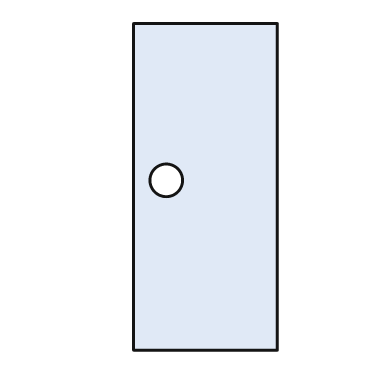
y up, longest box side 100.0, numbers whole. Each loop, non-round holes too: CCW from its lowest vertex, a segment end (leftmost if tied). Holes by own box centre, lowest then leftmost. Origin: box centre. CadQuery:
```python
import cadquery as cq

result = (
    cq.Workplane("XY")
    .moveTo(-22.0, -50.0)
    .lineTo(22.0, -50.0)
    .lineTo(22.0, 50.0)
    .lineTo(-22.0, 50.0)
    .close()
    .moveTo(-12.0, 2.0)
    .circle(5.0)
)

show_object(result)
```